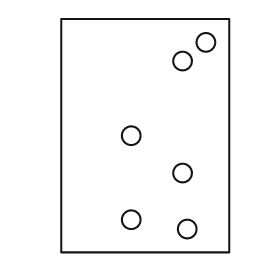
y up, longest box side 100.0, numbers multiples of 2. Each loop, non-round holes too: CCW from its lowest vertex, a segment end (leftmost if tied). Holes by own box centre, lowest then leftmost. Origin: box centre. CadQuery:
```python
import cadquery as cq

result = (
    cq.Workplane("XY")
    .moveTo(-36.0, -50.0)
    .lineTo(36.0, -50.0)
    .lineTo(36.0, 50.0)
    .lineTo(-36.0, 50.0)
    .close()
    .moveTo(18.0, -40.0)
    .circle(4.0)
    .moveTo(-6.0, -36.0)
    .circle(4.0)
    .moveTo(16.0, -16.0)
    .circle(4.0)
    .moveTo(-6.0, 0.0)
    .circle(4.0)
    .moveTo(16.0, 32.0)
    .circle(4.0)
    .moveTo(26.0, 40.0)
    .circle(4.0)
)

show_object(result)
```